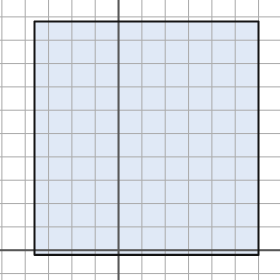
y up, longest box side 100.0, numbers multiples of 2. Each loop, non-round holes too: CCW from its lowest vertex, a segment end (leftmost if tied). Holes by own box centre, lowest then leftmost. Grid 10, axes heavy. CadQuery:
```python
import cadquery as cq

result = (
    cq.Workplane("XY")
    .moveTo(-36.0, -2.0)
    .lineTo(60.0, -2.0)
    .lineTo(60.0, 98.0)
    .lineTo(-36.0, 98.0)
    .close()
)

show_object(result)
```